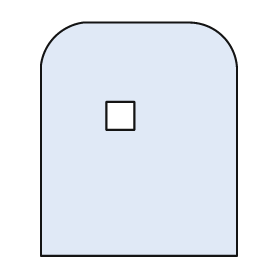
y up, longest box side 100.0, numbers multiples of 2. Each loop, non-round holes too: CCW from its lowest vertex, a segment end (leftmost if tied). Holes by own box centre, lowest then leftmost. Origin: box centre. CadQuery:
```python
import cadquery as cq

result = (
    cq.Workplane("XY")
    .moveTo(-42.0, -50.0)
    .lineTo(42.0, -50.0)
    .lineTo(42.0, 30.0)
    .threePointArc((36.0, 44.0), (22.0, 50.0))
    .lineTo(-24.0, 50.0)
    .threePointArc((-36.0, 44.0), (-42.0, 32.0))
    .close()
    .moveTo(-14.0, 4.0)
    .lineTo(-2.0, 4.0)
    .lineTo(-2.0, 16.0)
    .lineTo(-14.0, 16.0)
    .close()
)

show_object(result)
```